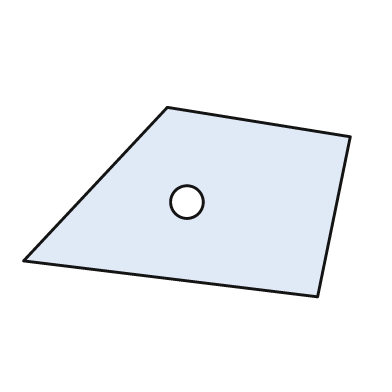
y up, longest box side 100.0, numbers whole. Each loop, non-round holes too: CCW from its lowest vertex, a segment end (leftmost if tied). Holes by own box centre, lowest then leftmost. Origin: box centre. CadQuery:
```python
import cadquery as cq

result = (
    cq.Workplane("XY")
    .moveTo(40.0, -29.0)
    .lineTo(50.0, 20.0)
    .lineTo(-6.0, 29.0)
    .lineTo(-50.0, -18.0)
    .close()
    .moveTo(0.0, 0.0)
    .circle(5.0)
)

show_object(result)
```